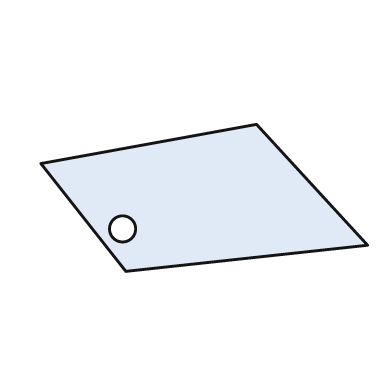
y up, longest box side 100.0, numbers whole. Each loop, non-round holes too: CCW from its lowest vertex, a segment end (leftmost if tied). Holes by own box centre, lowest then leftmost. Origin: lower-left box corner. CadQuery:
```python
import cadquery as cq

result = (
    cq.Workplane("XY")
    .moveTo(26.0, 0.0)
    .lineTo(100.0, 8.0)
    .lineTo(66.0, 45.0)
    .lineTo(0.0, 33.0)
    .close()
    .moveTo(25.0, 13.0)
    .circle(4.0)
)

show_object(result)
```